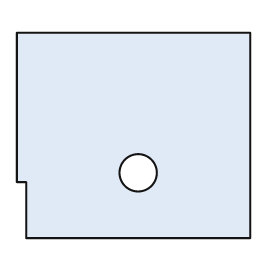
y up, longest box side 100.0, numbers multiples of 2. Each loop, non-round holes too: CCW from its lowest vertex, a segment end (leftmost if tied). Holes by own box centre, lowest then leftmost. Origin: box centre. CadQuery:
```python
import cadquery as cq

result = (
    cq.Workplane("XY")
    .moveTo(-46.0, -44.0)
    .lineTo(50.0, -44.0)
    .lineTo(50.0, 44.0)
    .lineTo(-50.0, 44.0)
    .lineTo(-50.0, -20.0)
    .lineTo(-46.0, -20.0)
    .close()
    .moveTo(2.0, -16.0)
    .circle(8.0)
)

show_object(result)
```